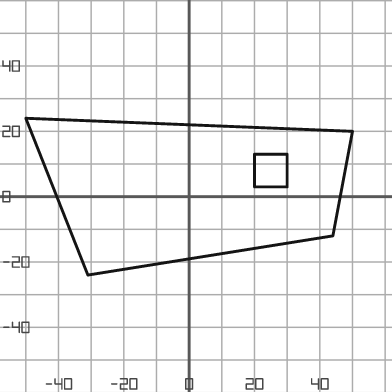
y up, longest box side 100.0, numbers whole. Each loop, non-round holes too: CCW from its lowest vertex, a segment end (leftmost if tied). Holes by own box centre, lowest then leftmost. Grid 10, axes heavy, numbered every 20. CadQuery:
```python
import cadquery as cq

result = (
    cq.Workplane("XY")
    .moveTo(-31.0, -24.0)
    .lineTo(44.0, -12.0)
    .lineTo(50.0, 20.0)
    .lineTo(-50.0, 24.0)
    .close()
    .moveTo(20.0, 3.0)
    .lineTo(30.0, 3.0)
    .lineTo(30.0, 13.0)
    .lineTo(20.0, 13.0)
    .close()
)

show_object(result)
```